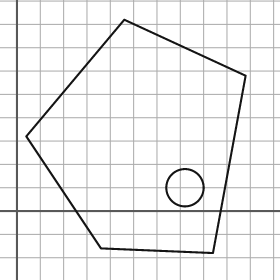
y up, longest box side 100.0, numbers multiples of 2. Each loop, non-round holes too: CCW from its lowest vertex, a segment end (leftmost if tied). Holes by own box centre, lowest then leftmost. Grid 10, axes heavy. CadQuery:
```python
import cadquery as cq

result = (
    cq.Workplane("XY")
    .moveTo(84.0, -18.0)
    .lineTo(98.0, 58.0)
    .lineTo(46.0, 82.0)
    .lineTo(4.0, 32.0)
    .lineTo(36.0, -16.0)
    .close()
    .moveTo(72.0, 10.0)
    .circle(8.0)
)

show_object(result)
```